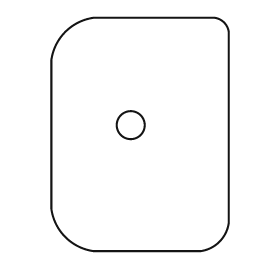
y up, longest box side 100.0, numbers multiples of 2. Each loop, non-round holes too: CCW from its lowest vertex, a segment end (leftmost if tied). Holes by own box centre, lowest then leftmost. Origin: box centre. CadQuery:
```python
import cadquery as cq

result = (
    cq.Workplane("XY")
    .moveTo(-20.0, -50.0)
    .lineTo(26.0, -50.0)
    .threePointArc((34.0, -46.0), (38.0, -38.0))
    .lineTo(38.0, 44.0)
    .threePointArc((36.0, 48.0), (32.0, 50.0))
    .lineTo(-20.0, 50.0)
    .threePointArc((-32.0, 44.0), (-38.0, 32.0))
    .lineTo(-38.0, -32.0)
    .threePointArc((-32.0, -44.0), (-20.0, -50.0))
    .close()
    .moveTo(-4.0, 4.0)
    .circle(6.0)
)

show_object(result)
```